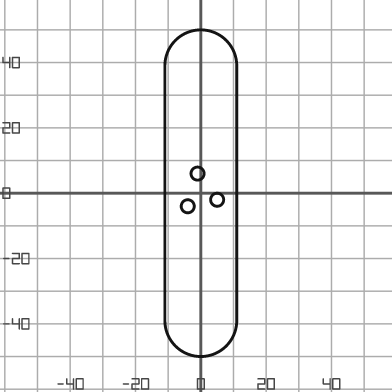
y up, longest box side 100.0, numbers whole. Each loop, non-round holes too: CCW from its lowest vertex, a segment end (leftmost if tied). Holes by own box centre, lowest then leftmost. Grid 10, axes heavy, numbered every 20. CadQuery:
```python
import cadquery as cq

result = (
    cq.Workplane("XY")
    .moveTo(-11.0, -39.0)
    .threePointArc((0.0, -50.0), (11.0, -39.0))
    .lineTo(11.0, 39.0)
    .threePointArc((0.0, 50.0), (-11.0, 39.0))
    .close()
    .moveTo(-4.0, -4.0)
    .circle(2.0)
    .moveTo(5.0, -2.0)
    .circle(2.0)
    .moveTo(-1.0, 6.0)
    .circle(2.0)
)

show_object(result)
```